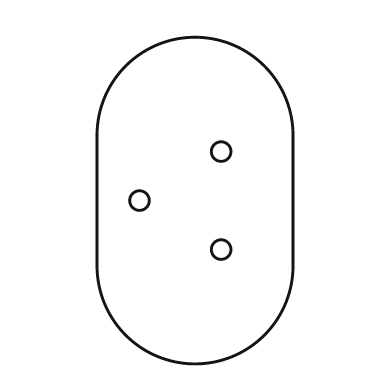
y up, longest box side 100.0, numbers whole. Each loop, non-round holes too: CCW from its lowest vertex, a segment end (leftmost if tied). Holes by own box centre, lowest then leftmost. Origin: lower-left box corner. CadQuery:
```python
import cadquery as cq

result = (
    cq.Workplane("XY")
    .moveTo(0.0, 30.0)
    .threePointArc((30.0, 0.0), (60.0, 30.0))
    .lineTo(60.0, 70.0)
    .threePointArc((30.0, 100.0), (0.0, 70.0))
    .close()
    .moveTo(38.0, 35.0)
    .circle(3.0)
    .moveTo(13.0, 50.0)
    .circle(3.0)
    .moveTo(38.0, 65.0)
    .circle(3.0)
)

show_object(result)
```